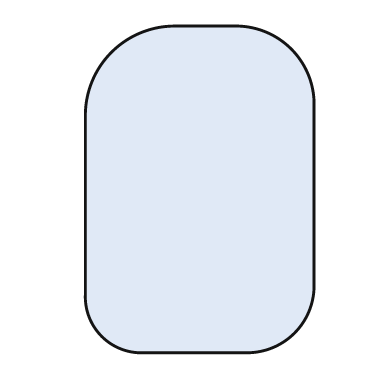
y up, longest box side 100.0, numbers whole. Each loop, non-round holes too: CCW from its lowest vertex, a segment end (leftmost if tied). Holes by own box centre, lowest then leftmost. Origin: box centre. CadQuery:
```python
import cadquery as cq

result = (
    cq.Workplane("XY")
    .moveTo(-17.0, -50.0)
    .lineTo(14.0, -50.0)
    .threePointArc((29.0, -44.0), (35.0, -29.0))
    .lineTo(35.0, 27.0)
    .threePointArc((28.0, 43.0), (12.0, 50.0))
    .lineTo(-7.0, 50.0)
    .threePointArc((-27.0, 42.0), (-35.0, 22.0))
    .lineTo(-35.0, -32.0)
    .threePointArc((-30.0, -45.0), (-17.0, -50.0))
    .close()
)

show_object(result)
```